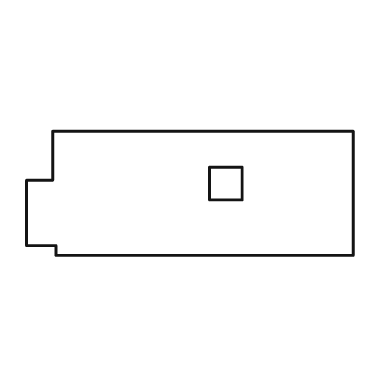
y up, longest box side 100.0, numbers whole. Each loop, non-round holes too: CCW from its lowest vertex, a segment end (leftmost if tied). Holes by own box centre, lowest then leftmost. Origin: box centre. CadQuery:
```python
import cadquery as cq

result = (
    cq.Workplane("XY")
    .moveTo(-41.0, -19.0)
    .lineTo(50.0, -19.0)
    .lineTo(50.0, 19.0)
    .lineTo(-42.0, 19.0)
    .lineTo(-42.0, 4.0)
    .lineTo(-50.0, 4.0)
    .lineTo(-50.0, -16.0)
    .lineTo(-41.0, -16.0)
    .close()
    .moveTo(6.0, -2.0)
    .lineTo(16.0, -2.0)
    .lineTo(16.0, 8.0)
    .lineTo(6.0, 8.0)
    .close()
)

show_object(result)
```